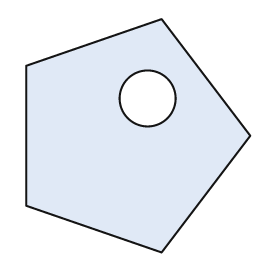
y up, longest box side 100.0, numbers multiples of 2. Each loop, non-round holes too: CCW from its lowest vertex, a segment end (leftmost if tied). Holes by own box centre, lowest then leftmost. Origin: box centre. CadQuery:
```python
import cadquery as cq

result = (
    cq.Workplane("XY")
    .moveTo(10.0, -50.0)
    .lineTo(48.0, 0.0)
    .lineTo(10.0, 50.0)
    .lineTo(-48.0, 30.0)
    .lineTo(-48.0, -30.0)
    .close()
    .moveTo(4.0, 16.0)
    .circle(12.0)
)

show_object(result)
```